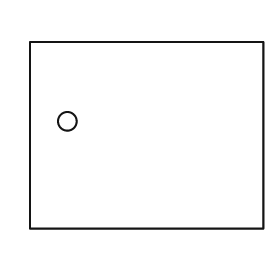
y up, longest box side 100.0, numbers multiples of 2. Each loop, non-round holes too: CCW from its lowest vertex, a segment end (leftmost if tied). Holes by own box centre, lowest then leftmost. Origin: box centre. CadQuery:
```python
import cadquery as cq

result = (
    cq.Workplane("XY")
    .moveTo(-50.0, -40.0)
    .lineTo(50.0, -40.0)
    .lineTo(50.0, 40.0)
    .lineTo(-50.0, 40.0)
    .close()
    .moveTo(-34.0, 6.0)
    .circle(4.0)
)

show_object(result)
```